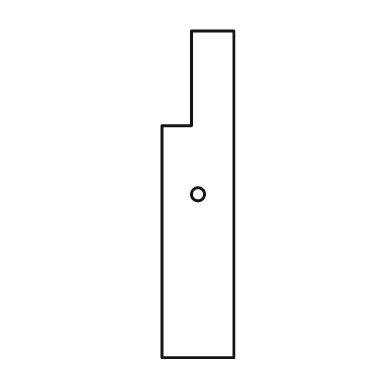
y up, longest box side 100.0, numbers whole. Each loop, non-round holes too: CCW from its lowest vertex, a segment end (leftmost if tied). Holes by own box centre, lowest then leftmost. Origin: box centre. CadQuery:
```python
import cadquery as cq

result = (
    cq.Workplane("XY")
    .moveTo(-11.0, -50.0)
    .lineTo(11.0, -50.0)
    .lineTo(11.0, 50.0)
    .lineTo(-2.0, 50.0)
    .lineTo(-2.0, 21.0)
    .lineTo(-11.0, 21.0)
    .close()
    .moveTo(0.0, 0.0)
    .circle(2.0)
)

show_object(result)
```